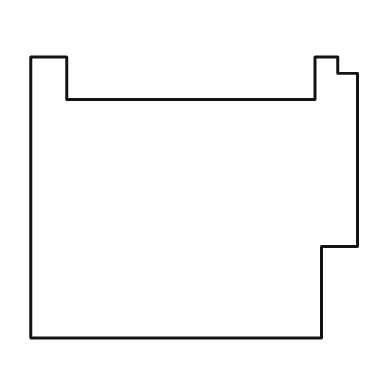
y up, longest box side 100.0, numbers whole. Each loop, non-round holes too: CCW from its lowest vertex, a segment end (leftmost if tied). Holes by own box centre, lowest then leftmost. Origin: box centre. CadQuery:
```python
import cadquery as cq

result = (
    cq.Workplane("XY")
    .moveTo(-50.0, -43.0)
    .lineTo(39.0, -43.0)
    .lineTo(39.0, -15.0)
    .lineTo(50.0, -15.0)
    .lineTo(50.0, 38.0)
    .lineTo(44.0, 38.0)
    .lineTo(44.0, 43.0)
    .lineTo(37.0, 43.0)
    .lineTo(37.0, 30.0)
    .lineTo(-39.0, 30.0)
    .lineTo(-39.0, 43.0)
    .lineTo(-50.0, 43.0)
    .close()
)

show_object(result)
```